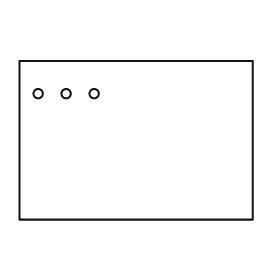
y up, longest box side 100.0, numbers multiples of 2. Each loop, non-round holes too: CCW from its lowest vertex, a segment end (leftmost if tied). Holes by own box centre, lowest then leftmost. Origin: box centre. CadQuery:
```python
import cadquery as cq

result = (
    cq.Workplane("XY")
    .moveTo(-50.0, -34.0)
    .lineTo(50.0, -34.0)
    .lineTo(50.0, 34.0)
    .lineTo(-50.0, 34.0)
    .close()
    .moveTo(-42.0, 20.0)
    .circle(2.0)
    .moveTo(-30.0, 20.0)
    .circle(2.0)
    .moveTo(-18.0, 20.0)
    .circle(2.0)
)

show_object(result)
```